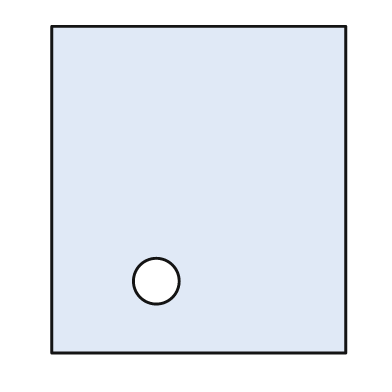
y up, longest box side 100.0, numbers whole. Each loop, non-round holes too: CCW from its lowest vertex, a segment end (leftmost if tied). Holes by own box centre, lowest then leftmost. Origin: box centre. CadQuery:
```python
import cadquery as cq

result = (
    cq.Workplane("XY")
    .moveTo(-45.0, -50.0)
    .lineTo(45.0, -50.0)
    .lineTo(45.0, 50.0)
    .lineTo(-45.0, 50.0)
    .close()
    .moveTo(-13.0, -28.0)
    .circle(7.0)
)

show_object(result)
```